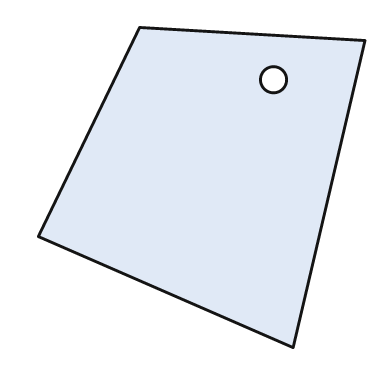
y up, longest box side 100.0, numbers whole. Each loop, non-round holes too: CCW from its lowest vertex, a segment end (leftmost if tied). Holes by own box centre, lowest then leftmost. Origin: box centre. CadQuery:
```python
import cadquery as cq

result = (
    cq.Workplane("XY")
    .moveTo(28.0, -49.0)
    .lineTo(50.0, 45.0)
    .lineTo(-19.0, 49.0)
    .lineTo(-50.0, -15.0)
    .close()
    .moveTo(22.0, 33.0)
    .circle(4.0)
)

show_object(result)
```